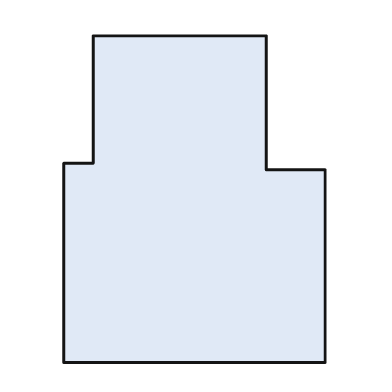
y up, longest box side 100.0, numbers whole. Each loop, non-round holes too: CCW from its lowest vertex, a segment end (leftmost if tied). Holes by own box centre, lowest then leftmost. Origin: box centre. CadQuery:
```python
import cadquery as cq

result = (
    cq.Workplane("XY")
    .moveTo(-40.0, -50.0)
    .lineTo(40.0, -50.0)
    .lineTo(40.0, 9.0)
    .lineTo(22.0, 9.0)
    .lineTo(22.0, 50.0)
    .lineTo(-31.0, 50.0)
    .lineTo(-31.0, 11.0)
    .lineTo(-40.0, 11.0)
    .close()
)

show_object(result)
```